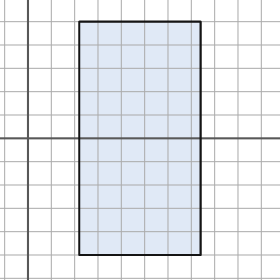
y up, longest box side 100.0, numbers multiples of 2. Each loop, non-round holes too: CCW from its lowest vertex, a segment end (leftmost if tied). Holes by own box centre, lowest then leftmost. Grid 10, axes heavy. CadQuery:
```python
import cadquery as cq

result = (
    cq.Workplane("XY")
    .moveTo(22.0, -50.0)
    .lineTo(74.0, -50.0)
    .lineTo(74.0, 50.0)
    .lineTo(22.0, 50.0)
    .close()
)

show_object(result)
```